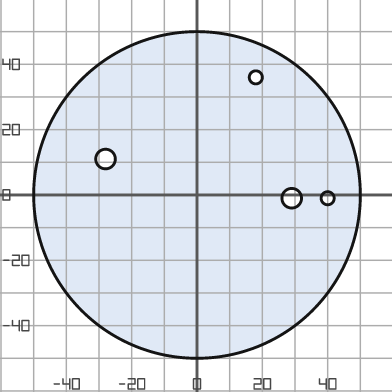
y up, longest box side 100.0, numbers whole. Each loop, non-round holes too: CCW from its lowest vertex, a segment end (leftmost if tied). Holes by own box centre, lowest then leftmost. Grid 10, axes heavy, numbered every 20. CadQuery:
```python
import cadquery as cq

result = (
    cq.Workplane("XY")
    .moveTo(0.0, 0.0)
    .circle(50.0)
    .moveTo(29.0, -1.0)
    .circle(3.0)
    .moveTo(40.0, -1.0)
    .circle(2.0)
    .moveTo(-28.0, 11.0)
    .circle(3.0)
    .moveTo(18.0, 36.0)
    .circle(2.0)
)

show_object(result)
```